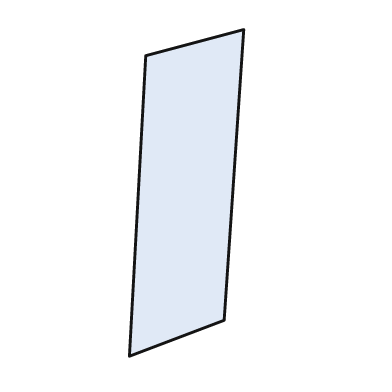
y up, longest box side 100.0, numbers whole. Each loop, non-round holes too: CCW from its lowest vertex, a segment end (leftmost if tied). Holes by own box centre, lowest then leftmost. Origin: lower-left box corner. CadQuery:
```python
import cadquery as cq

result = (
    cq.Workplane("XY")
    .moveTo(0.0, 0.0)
    .lineTo(29.0, 11.0)
    .lineTo(35.0, 100.0)
    .lineTo(5.0, 92.0)
    .close()
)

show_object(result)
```